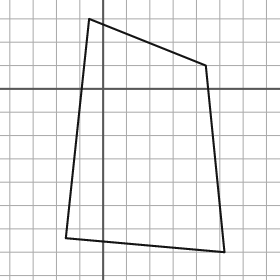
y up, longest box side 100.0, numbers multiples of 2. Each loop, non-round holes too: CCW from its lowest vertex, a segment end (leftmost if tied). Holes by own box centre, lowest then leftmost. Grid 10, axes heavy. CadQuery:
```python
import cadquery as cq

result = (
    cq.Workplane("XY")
    .moveTo(52.0, -70.0)
    .lineTo(44.0, 10.0)
    .lineTo(-6.0, 30.0)
    .lineTo(-16.0, -64.0)
    .close()
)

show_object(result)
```